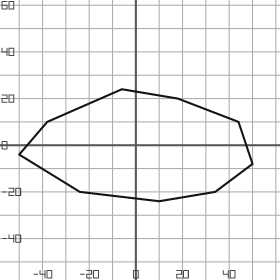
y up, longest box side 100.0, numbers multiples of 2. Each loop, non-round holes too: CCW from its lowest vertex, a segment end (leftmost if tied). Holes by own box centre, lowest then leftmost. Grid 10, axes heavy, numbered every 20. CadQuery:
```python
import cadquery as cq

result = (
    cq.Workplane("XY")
    .moveTo(10.0, -24.0)
    .lineTo(34.0, -20.0)
    .lineTo(50.0, -8.0)
    .lineTo(44.0, 10.0)
    .lineTo(18.0, 20.0)
    .lineTo(-6.0, 24.0)
    .lineTo(-38.0, 10.0)
    .lineTo(-50.0, -4.0)
    .lineTo(-24.0, -20.0)
    .close()
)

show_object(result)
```